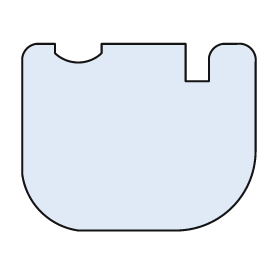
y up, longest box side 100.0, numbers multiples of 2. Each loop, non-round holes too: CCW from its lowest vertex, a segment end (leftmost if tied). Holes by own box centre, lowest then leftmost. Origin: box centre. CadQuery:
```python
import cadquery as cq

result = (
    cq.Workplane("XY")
    .moveTo(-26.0, -40.0)
    .lineTo(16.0, -40.0)
    .threePointArc((40.0, -30.0), (50.0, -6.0))
    .lineTo(50.0, 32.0)
    .threePointArc((48.0, 38.0), (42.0, 40.0))
    .lineTo(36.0, 40.0)
    .threePointArc((32.0, 38.0), (30.0, 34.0))
    .lineTo(30.0, 24.0)
    .lineTo(20.0, 24.0)
    .lineTo(20.0, 40.0)
    .lineTo(-16.0, 40.0)
    .lineTo(-16.0, 36.0)
    .threePointArc((-26.0, 32.0), (-36.0, 36.0))
    .lineTo(-36.0, 40.0)
    .lineTo(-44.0, 40.0)
    .threePointArc((-48.0, 38.0), (-50.0, 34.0))
    .lineTo(-50.0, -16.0)
    .threePointArc((-42.0, -32.0), (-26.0, -40.0))
    .close()
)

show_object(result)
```